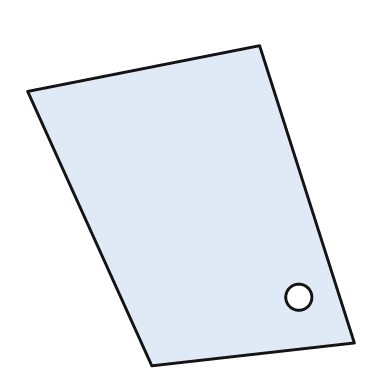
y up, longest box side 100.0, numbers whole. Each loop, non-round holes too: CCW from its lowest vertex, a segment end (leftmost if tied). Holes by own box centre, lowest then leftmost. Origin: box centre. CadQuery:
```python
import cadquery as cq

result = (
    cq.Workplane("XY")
    .moveTo(-12.0, -49.0)
    .lineTo(50.0, -42.0)
    .lineTo(21.0, 49.0)
    .lineTo(-50.0, 35.0)
    .close()
    .moveTo(33.0, -28.0)
    .circle(4.0)
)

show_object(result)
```